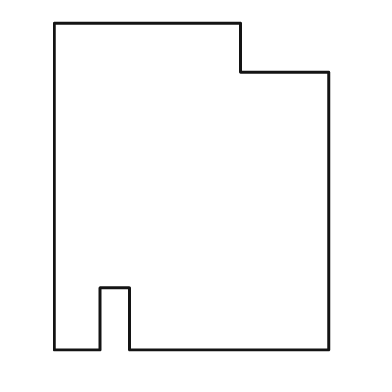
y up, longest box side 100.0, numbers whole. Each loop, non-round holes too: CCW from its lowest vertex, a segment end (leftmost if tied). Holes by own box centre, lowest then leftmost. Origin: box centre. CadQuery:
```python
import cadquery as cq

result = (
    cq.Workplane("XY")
    .moveTo(-42.0, -50.0)
    .lineTo(-28.0, -50.0)
    .lineTo(-28.0, -31.0)
    .lineTo(-19.0, -31.0)
    .lineTo(-19.0, -50.0)
    .lineTo(42.0, -50.0)
    .lineTo(42.0, 35.0)
    .lineTo(15.0, 35.0)
    .lineTo(15.0, 50.0)
    .lineTo(-42.0, 50.0)
    .close()
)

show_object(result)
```